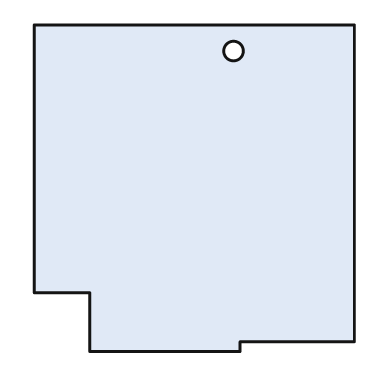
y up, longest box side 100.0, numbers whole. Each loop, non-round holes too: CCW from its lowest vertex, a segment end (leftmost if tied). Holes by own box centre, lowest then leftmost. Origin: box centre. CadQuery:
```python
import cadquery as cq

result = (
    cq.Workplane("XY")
    .moveTo(-32.0, -50.0)
    .lineTo(14.0, -50.0)
    .lineTo(14.0, -47.0)
    .lineTo(49.0, -47.0)
    .lineTo(49.0, 50.0)
    .lineTo(-49.0, 50.0)
    .lineTo(-49.0, -32.0)
    .lineTo(-32.0, -32.0)
    .close()
    .moveTo(12.0, 42.0)
    .circle(3.0)
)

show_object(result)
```